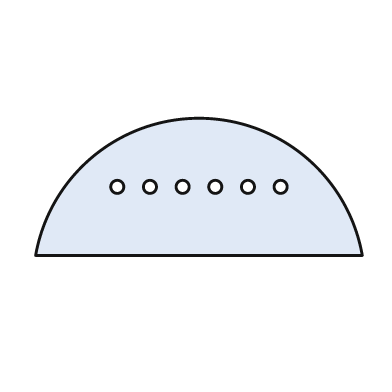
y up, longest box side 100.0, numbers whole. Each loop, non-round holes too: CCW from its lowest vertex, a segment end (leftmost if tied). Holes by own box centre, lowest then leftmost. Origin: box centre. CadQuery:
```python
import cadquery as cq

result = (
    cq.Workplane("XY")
    .moveTo(-50.0, -21.0)
    .lineTo(50.0, -21.0)
    .threePointArc((0.0, 21.0), (-50.0, -21.0))
    .close()
    .moveTo(-25.0, 0.0)
    .circle(2.0)
    .moveTo(-15.0, 0.0)
    .circle(2.0)
    .moveTo(-5.0, 0.0)
    .circle(2.0)
    .moveTo(5.0, 0.0)
    .circle(2.0)
    .moveTo(15.0, 0.0)
    .circle(2.0)
    .moveTo(25.0, 0.0)
    .circle(2.0)
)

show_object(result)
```